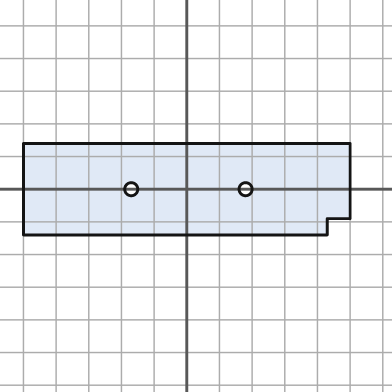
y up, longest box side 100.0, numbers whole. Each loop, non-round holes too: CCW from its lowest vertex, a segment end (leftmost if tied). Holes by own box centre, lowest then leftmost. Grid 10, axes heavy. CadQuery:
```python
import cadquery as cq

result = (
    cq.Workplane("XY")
    .moveTo(-50.0, -14.0)
    .lineTo(43.0, -14.0)
    .lineTo(43.0, -9.0)
    .lineTo(50.0, -9.0)
    .lineTo(50.0, 14.0)
    .lineTo(-50.0, 14.0)
    .close()
    .moveTo(-17.0, 0.0)
    .circle(2.0)
    .moveTo(18.0, 0.0)
    .circle(2.0)
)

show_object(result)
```